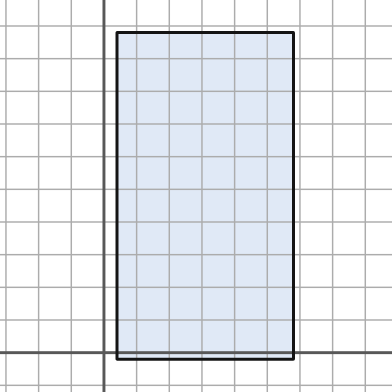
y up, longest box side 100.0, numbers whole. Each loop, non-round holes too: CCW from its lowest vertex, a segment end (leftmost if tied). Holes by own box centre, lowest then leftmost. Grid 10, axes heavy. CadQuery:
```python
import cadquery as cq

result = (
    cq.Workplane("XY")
    .moveTo(4.0, -2.0)
    .lineTo(58.0, -2.0)
    .lineTo(58.0, 98.0)
    .lineTo(4.0, 98.0)
    .close()
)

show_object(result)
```